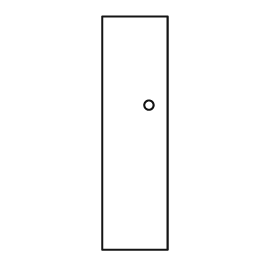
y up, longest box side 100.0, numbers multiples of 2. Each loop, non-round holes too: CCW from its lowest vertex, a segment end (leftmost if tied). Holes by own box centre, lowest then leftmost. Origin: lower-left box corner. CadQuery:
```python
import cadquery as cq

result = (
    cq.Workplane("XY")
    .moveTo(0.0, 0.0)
    .lineTo(28.0, 0.0)
    .lineTo(28.0, 100.0)
    .lineTo(0.0, 100.0)
    .close()
    .moveTo(20.0, 62.0)
    .circle(2.0)
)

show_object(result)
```